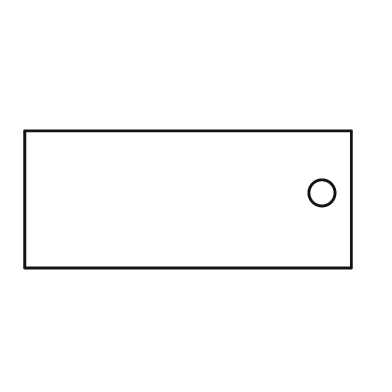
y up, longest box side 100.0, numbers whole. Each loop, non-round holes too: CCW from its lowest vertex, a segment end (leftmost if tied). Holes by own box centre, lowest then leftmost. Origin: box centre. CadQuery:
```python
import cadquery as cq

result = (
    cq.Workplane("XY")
    .moveTo(-50.0, -21.0)
    .lineTo(50.0, -21.0)
    .lineTo(50.0, 21.0)
    .lineTo(-50.0, 21.0)
    .close()
    .moveTo(41.0, 2.0)
    .circle(4.0)
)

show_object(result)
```